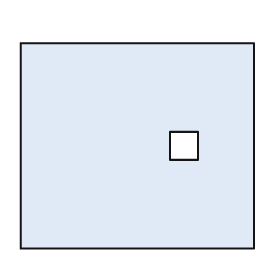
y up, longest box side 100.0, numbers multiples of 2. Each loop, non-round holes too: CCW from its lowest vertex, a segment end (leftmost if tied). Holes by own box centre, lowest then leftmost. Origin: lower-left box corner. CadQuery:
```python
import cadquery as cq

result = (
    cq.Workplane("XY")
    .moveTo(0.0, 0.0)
    .lineTo(100.0, 0.0)
    .lineTo(100.0, 88.0)
    .lineTo(0.0, 88.0)
    .close()
    .moveTo(64.0, 38.0)
    .lineTo(76.0, 38.0)
    .lineTo(76.0, 50.0)
    .lineTo(64.0, 50.0)
    .close()
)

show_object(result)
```